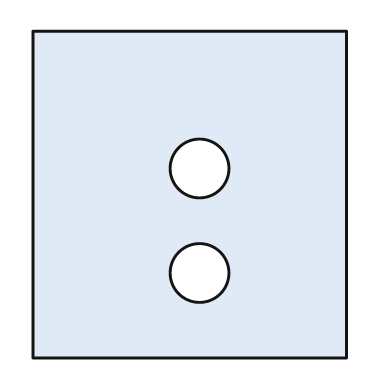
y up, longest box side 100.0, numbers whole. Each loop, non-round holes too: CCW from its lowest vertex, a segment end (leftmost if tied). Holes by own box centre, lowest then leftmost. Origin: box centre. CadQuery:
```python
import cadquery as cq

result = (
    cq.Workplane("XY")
    .moveTo(-48.0, -50.0)
    .lineTo(48.0, -50.0)
    .lineTo(48.0, 50.0)
    .lineTo(-48.0, 50.0)
    .close()
    .moveTo(3.0, -24.0)
    .circle(9.0)
    .moveTo(3.0, 8.0)
    .circle(9.0)
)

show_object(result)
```